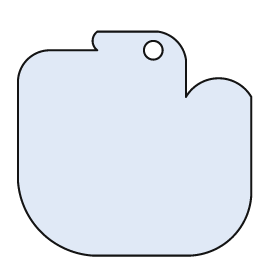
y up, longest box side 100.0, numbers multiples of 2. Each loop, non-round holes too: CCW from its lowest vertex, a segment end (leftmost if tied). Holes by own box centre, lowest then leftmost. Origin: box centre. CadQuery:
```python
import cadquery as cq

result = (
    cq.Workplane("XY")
    .moveTo(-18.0, -48.0)
    .lineTo(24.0, -48.0)
    .threePointArc((42.0, -40.0), (50.0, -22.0))
    .lineTo(50.0, 20.0)
    .threePointArc((36.0, 28.0), (22.0, 20.0))
    .lineTo(22.0, 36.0)
    .threePointArc((18.0, 44.0), (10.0, 48.0))
    .lineTo(-16.0, 48.0)
    .threePointArc((-18.0, 44.0), (-16.0, 40.0))
    .lineTo(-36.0, 40.0)
    .threePointArc((-46.0, 36.0), (-50.0, 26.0))
    .lineTo(-50.0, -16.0)
    .threePointArc((-40.0, -38.0), (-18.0, -48.0))
    .close()
    .moveTo(8.0, 40.0)
    .circle(4.0)
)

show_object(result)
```